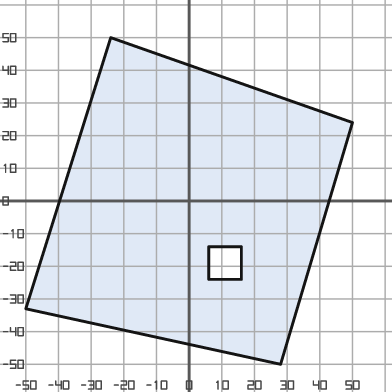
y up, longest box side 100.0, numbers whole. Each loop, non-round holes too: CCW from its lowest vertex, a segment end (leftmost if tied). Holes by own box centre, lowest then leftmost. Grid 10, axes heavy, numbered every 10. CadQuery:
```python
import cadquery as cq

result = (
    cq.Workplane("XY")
    .moveTo(28.0, -50.0)
    .lineTo(50.0, 24.0)
    .lineTo(-24.0, 50.0)
    .lineTo(-50.0, -33.0)
    .close()
    .moveTo(6.0, -24.0)
    .lineTo(16.0, -24.0)
    .lineTo(16.0, -14.0)
    .lineTo(6.0, -14.0)
    .close()
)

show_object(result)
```